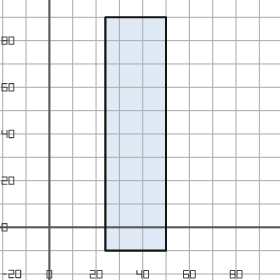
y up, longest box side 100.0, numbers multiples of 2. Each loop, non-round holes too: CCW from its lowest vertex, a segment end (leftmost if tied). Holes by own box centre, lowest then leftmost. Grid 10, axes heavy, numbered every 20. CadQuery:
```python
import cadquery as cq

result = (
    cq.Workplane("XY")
    .moveTo(24.0, -10.0)
    .lineTo(50.0, -10.0)
    .lineTo(50.0, 90.0)
    .lineTo(24.0, 90.0)
    .close()
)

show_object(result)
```